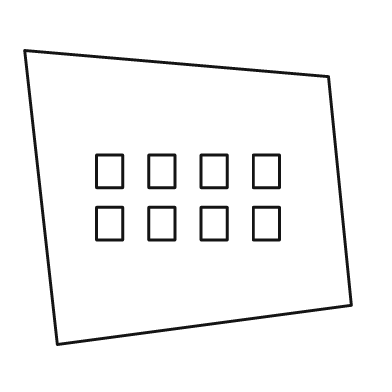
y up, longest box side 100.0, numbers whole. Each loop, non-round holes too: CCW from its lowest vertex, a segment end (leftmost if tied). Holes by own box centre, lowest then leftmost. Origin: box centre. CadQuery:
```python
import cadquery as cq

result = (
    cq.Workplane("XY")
    .moveTo(-40.0, -45.0)
    .lineTo(50.0, -33.0)
    .lineTo(43.0, 37.0)
    .lineTo(-50.0, 45.0)
    .close()
    .moveTo(-28.0, -13.0)
    .lineTo(-20.0, -13.0)
    .lineTo(-20.0, -3.0)
    .lineTo(-28.0, -3.0)
    .close()
    .moveTo(-12.0, -13.0)
    .lineTo(-4.0, -13.0)
    .lineTo(-4.0, -3.0)
    .lineTo(-12.0, -3.0)
    .close()
    .moveTo(4.0, -13.0)
    .lineTo(12.0, -13.0)
    .lineTo(12.0, -3.0)
    .lineTo(4.0, -3.0)
    .close()
    .moveTo(20.0, -13.0)
    .lineTo(28.0, -13.0)
    .lineTo(28.0, -3.0)
    .lineTo(20.0, -3.0)
    .close()
    .moveTo(-28.0, 3.0)
    .lineTo(-20.0, 3.0)
    .lineTo(-20.0, 13.0)
    .lineTo(-28.0, 13.0)
    .close()
    .moveTo(-12.0, 3.0)
    .lineTo(-4.0, 3.0)
    .lineTo(-4.0, 13.0)
    .lineTo(-12.0, 13.0)
    .close()
    .moveTo(4.0, 3.0)
    .lineTo(12.0, 3.0)
    .lineTo(12.0, 13.0)
    .lineTo(4.0, 13.0)
    .close()
    .moveTo(20.0, 3.0)
    .lineTo(28.0, 3.0)
    .lineTo(28.0, 13.0)
    .lineTo(20.0, 13.0)
    .close()
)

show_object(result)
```